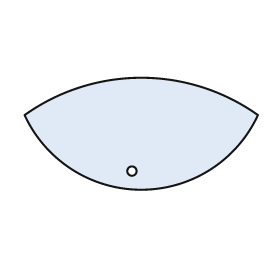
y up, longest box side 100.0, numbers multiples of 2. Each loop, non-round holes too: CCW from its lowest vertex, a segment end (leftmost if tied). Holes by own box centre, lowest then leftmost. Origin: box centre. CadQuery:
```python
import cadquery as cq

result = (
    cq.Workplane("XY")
    .moveTo(-50.0, 8.0)
    .threePointArc((0.0, -24.0), (50.0, 8.0))
    .threePointArc((0.0, 24.0), (-50.0, 8.0))
    .close()
    .moveTo(-4.0, -16.0)
    .circle(2.0)
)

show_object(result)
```